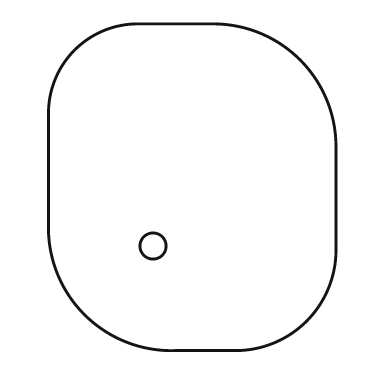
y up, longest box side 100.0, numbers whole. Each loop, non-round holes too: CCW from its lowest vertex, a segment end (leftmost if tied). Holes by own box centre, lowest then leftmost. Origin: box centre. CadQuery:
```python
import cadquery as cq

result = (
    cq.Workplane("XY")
    .moveTo(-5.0, -50.0)
    .lineTo(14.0, -50.0)
    .threePointArc((35.0, -41.0), (44.0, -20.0))
    .lineTo(44.0, 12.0)
    .threePointArc((33.0, 39.0), (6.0, 50.0))
    .lineTo(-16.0, 50.0)
    .threePointArc((-36.0, 42.0), (-44.0, 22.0))
    .lineTo(-44.0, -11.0)
    .threePointArc((-33.0, -39.0), (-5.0, -50.0))
    .close()
    .moveTo(-12.0, -18.0)
    .circle(4.0)
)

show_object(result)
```